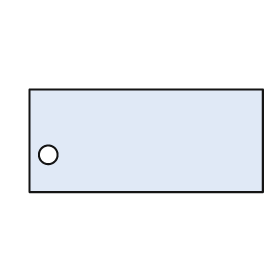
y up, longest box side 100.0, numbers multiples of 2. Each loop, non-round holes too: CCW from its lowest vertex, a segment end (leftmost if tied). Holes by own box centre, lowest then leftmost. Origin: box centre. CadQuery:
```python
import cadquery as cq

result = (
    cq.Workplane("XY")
    .moveTo(-50.0, -22.0)
    .lineTo(50.0, -22.0)
    .lineTo(50.0, 22.0)
    .lineTo(-50.0, 22.0)
    .close()
    .moveTo(-42.0, -6.0)
    .circle(4.0)
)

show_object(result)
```